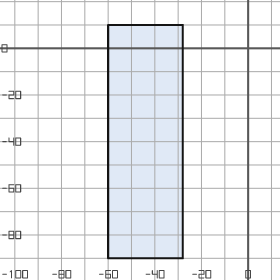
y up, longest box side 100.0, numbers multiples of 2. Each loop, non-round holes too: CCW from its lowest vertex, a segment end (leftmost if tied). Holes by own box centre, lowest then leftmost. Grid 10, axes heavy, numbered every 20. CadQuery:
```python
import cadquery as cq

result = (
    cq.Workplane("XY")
    .moveTo(-60.0, -90.0)
    .lineTo(-28.0, -90.0)
    .lineTo(-28.0, 10.0)
    .lineTo(-60.0, 10.0)
    .close()
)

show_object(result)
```